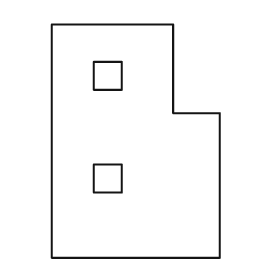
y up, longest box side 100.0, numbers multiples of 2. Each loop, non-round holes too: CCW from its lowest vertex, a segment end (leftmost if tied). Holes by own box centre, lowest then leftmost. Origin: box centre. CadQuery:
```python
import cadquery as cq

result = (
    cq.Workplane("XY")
    .moveTo(-36.0, -50.0)
    .lineTo(36.0, -50.0)
    .lineTo(36.0, 12.0)
    .lineTo(16.0, 12.0)
    .lineTo(16.0, 50.0)
    .lineTo(-36.0, 50.0)
    .close()
    .moveTo(-18.0, -22.0)
    .lineTo(-6.0, -22.0)
    .lineTo(-6.0, -10.0)
    .lineTo(-18.0, -10.0)
    .close()
    .moveTo(-18.0, 22.0)
    .lineTo(-6.0, 22.0)
    .lineTo(-6.0, 34.0)
    .lineTo(-18.0, 34.0)
    .close()
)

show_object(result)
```